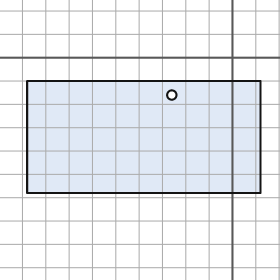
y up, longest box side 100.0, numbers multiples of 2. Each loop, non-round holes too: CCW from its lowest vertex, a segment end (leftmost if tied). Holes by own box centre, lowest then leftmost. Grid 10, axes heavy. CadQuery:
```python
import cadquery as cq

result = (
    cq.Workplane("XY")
    .moveTo(-88.0, -58.0)
    .lineTo(12.0, -58.0)
    .lineTo(12.0, -10.0)
    .lineTo(-88.0, -10.0)
    .close()
    .moveTo(-26.0, -16.0)
    .circle(2.0)
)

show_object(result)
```